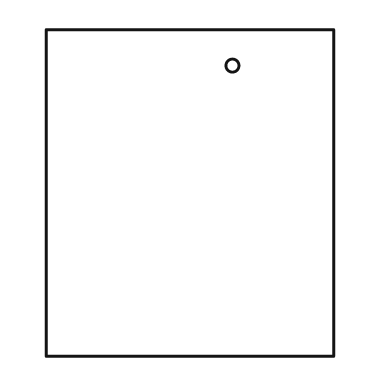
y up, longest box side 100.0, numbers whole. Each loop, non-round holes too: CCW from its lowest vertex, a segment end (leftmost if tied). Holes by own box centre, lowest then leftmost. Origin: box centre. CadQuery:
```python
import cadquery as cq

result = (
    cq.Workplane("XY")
    .moveTo(-44.0, -50.0)
    .lineTo(44.0, -50.0)
    .lineTo(44.0, 50.0)
    .lineTo(-44.0, 50.0)
    .close()
    .moveTo(13.0, 39.0)
    .circle(2.0)
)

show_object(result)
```